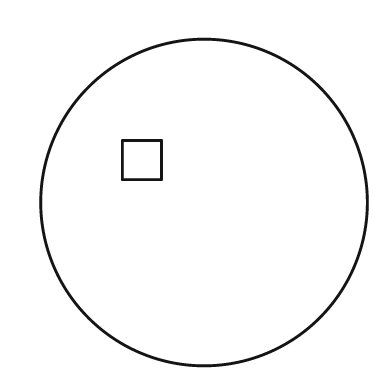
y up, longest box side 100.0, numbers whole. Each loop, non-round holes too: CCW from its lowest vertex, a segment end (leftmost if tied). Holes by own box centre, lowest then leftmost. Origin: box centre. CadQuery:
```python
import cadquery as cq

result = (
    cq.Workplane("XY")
    .moveTo(0.0, 0.0)
    .circle(50.0)
    .moveTo(-25.0, 7.0)
    .lineTo(-13.0, 7.0)
    .lineTo(-13.0, 19.0)
    .lineTo(-25.0, 19.0)
    .close()
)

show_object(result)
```